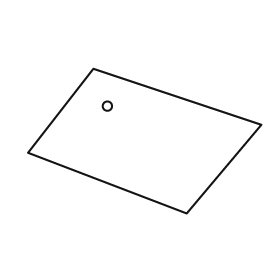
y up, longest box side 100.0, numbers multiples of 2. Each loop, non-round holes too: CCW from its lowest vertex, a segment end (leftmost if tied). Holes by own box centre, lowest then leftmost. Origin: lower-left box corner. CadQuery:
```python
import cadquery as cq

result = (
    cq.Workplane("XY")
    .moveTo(68.0, 0.0)
    .lineTo(100.0, 38.0)
    .lineTo(28.0, 62.0)
    .lineTo(0.0, 26.0)
    .close()
    .moveTo(34.0, 46.0)
    .circle(2.0)
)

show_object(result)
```